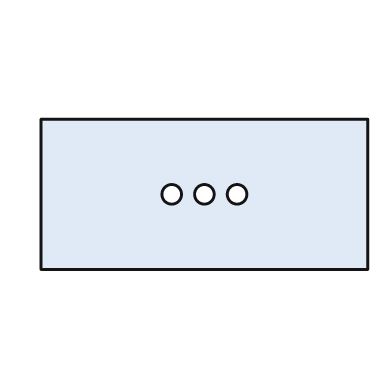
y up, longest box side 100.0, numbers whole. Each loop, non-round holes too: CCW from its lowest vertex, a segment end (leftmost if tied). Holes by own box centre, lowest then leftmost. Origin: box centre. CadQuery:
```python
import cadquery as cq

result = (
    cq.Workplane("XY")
    .moveTo(-50.0, -23.0)
    .lineTo(50.0, -23.0)
    .lineTo(50.0, 23.0)
    .lineTo(-50.0, 23.0)
    .close()
    .moveTo(-10.0, 0.0)
    .circle(3.0)
    .moveTo(0.0, 0.0)
    .circle(3.0)
    .moveTo(10.0, 0.0)
    .circle(3.0)
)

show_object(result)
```